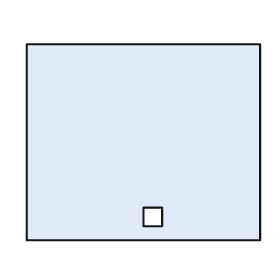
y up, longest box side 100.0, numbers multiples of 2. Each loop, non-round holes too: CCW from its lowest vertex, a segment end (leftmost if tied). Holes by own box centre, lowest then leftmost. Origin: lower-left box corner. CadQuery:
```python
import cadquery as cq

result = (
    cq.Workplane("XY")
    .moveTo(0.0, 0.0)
    .lineTo(100.0, 0.0)
    .lineTo(100.0, 84.0)
    .lineTo(0.0, 84.0)
    .close()
    .moveTo(50.0, 6.0)
    .lineTo(58.0, 6.0)
    .lineTo(58.0, 14.0)
    .lineTo(50.0, 14.0)
    .close()
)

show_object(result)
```